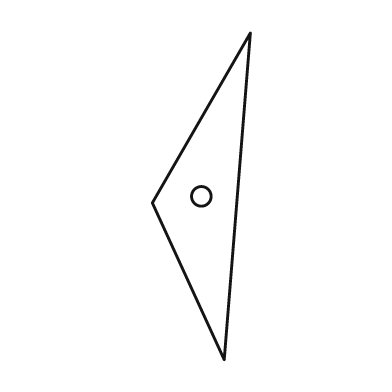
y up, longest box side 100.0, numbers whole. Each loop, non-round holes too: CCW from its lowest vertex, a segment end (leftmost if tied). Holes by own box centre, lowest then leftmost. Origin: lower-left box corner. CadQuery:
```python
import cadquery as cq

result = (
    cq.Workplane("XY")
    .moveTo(22.0, 0.0)
    .lineTo(30.0, 100.0)
    .lineTo(0.0, 48.0)
    .close()
    .moveTo(15.0, 50.0)
    .circle(3.0)
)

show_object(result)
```